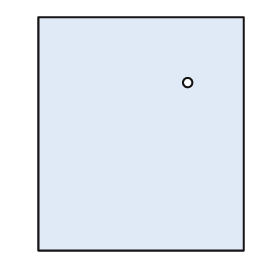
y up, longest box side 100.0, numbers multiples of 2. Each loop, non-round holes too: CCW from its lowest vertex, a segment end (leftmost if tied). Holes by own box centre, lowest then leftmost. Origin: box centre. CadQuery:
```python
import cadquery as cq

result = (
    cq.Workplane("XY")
    .moveTo(-44.0, -50.0)
    .lineTo(44.0, -50.0)
    .lineTo(44.0, 50.0)
    .lineTo(-44.0, 50.0)
    .close()
    .moveTo(20.0, 22.0)
    .circle(2.0)
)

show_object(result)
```